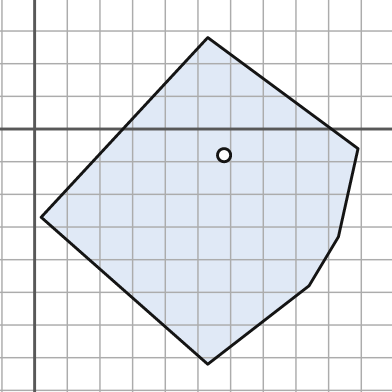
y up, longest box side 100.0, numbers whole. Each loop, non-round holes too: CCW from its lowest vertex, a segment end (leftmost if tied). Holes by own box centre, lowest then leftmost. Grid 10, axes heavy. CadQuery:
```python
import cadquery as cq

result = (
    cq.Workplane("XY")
    .moveTo(53.0, -72.0)
    .lineTo(84.0, -48.0)
    .lineTo(93.0, -33.0)
    .lineTo(99.0, -6.0)
    .lineTo(53.0, 28.0)
    .lineTo(2.0, -27.0)
    .close()
    .moveTo(58.0, -8.0)
    .circle(2.0)
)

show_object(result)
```